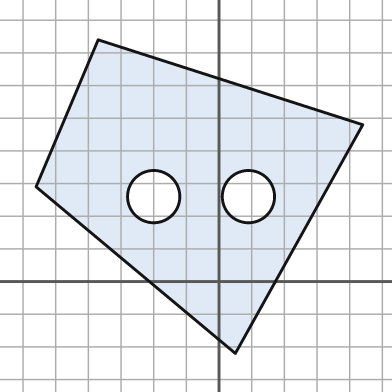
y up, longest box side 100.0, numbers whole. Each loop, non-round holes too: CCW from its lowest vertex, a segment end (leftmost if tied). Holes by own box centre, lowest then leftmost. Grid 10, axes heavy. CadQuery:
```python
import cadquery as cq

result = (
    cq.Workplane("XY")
    .moveTo(5.0, -22.0)
    .lineTo(44.0, 48.0)
    .lineTo(-37.0, 74.0)
    .lineTo(-56.0, 29.0)
    .close()
    .moveTo(-20.0, 26.0)
    .circle(8.0)
    .moveTo(9.0, 26.0)
    .circle(8.0)
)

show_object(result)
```